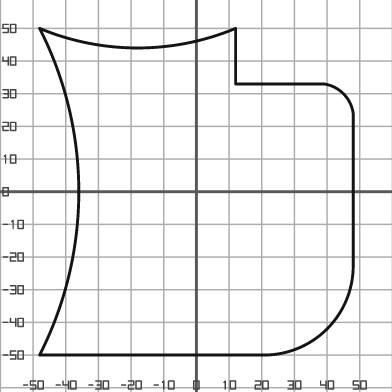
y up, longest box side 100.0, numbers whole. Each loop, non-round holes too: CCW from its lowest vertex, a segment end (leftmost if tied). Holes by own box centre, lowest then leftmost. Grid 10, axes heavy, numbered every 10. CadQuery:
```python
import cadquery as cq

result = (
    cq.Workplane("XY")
    .moveTo(-48.0, -50.0)
    .lineTo(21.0, -50.0)
    .threePointArc((40.0, -42.0), (48.0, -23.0))
    .lineTo(48.0, 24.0)
    .threePointArc((45.0, 30.0), (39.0, 33.0))
    .lineTo(12.0, 33.0)
    .lineTo(12.0, 50.0)
    .threePointArc((-18.0, 44.0), (-48.0, 50.0))
    .threePointArc((-36.0, 0.0), (-48.0, -50.0))
    .close()
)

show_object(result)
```